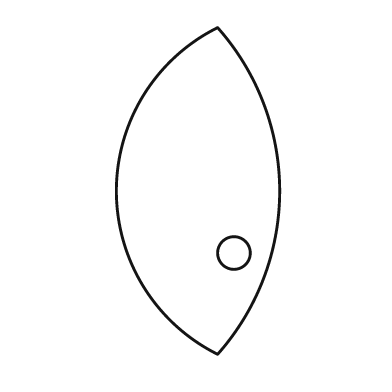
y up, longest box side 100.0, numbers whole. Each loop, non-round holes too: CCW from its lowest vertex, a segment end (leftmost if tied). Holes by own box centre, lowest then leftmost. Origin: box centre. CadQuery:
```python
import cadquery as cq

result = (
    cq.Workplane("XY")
    .moveTo(6.0, -50.0)
    .threePointArc((25.0, 0.0), (6.0, 50.0))
    .threePointArc((-25.0, 0.0), (6.0, -50.0))
    .close()
    .moveTo(11.0, -19.0)
    .circle(5.0)
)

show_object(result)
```